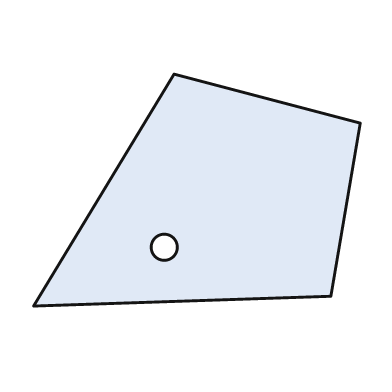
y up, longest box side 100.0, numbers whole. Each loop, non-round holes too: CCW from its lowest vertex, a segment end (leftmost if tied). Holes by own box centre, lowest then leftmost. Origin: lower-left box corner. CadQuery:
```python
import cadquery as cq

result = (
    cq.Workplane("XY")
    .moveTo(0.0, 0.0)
    .lineTo(91.0, 3.0)
    .lineTo(100.0, 56.0)
    .lineTo(43.0, 71.0)
    .close()
    .moveTo(40.0, 18.0)
    .circle(4.0)
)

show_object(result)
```